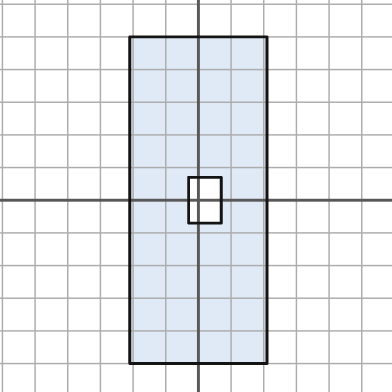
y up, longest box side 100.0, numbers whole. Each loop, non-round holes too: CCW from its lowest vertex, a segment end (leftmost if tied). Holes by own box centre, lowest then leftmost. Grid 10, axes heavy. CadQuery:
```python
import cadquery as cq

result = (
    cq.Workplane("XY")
    .moveTo(-21.0, -50.0)
    .lineTo(21.0, -50.0)
    .lineTo(21.0, 50.0)
    .lineTo(-21.0, 50.0)
    .close()
    .moveTo(-3.0, -7.0)
    .lineTo(7.0, -7.0)
    .lineTo(7.0, 7.0)
    .lineTo(-3.0, 7.0)
    .close()
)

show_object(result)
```